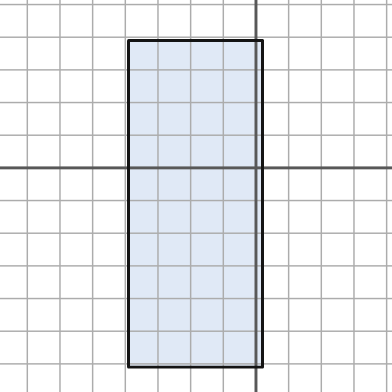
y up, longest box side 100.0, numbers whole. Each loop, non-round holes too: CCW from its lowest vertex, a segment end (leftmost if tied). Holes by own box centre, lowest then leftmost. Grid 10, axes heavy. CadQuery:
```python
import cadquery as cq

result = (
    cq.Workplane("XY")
    .moveTo(-39.0, -61.0)
    .lineTo(2.0, -61.0)
    .lineTo(2.0, 39.0)
    .lineTo(-39.0, 39.0)
    .close()
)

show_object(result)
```